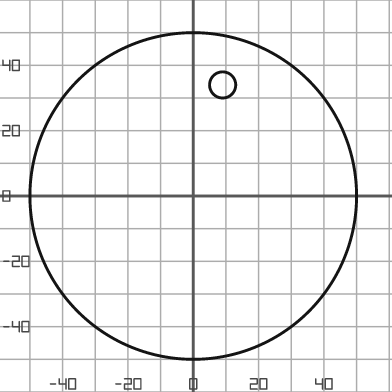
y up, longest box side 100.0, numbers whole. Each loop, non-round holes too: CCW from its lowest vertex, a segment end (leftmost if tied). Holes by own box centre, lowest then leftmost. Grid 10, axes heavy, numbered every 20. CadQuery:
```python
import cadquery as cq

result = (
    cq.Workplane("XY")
    .moveTo(0.0, 0.0)
    .circle(50.0)
    .moveTo(9.0, 34.0)
    .circle(4.0)
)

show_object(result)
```